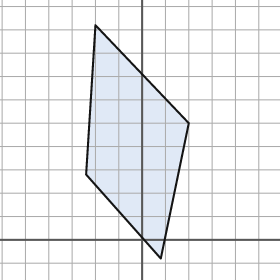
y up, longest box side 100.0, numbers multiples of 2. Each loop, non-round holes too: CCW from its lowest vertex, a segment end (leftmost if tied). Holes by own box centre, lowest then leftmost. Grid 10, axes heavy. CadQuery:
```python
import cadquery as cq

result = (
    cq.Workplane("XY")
    .moveTo(8.0, -8.0)
    .lineTo(20.0, 50.0)
    .lineTo(-20.0, 92.0)
    .lineTo(-24.0, 28.0)
    .close()
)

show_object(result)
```